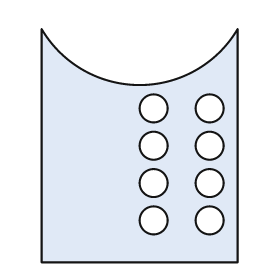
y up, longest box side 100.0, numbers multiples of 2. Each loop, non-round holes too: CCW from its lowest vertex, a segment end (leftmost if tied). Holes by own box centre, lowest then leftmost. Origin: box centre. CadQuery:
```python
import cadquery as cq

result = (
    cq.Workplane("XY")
    .moveTo(-42.0, -50.0)
    .lineTo(42.0, -50.0)
    .lineTo(42.0, 50.0)
    .threePointArc((0.0, 26.0), (-42.0, 50.0))
    .close()
    .moveTo(6.0, -32.0)
    .circle(6.0)
    .moveTo(30.0, -32.0)
    .circle(6.0)
    .moveTo(6.0, -16.0)
    .circle(6.0)
    .moveTo(30.0, -16.0)
    .circle(6.0)
    .moveTo(6.0, 0.0)
    .circle(6.0)
    .moveTo(30.0, 0.0)
    .circle(6.0)
    .moveTo(6.0, 16.0)
    .circle(6.0)
    .moveTo(30.0, 16.0)
    .circle(6.0)
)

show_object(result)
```